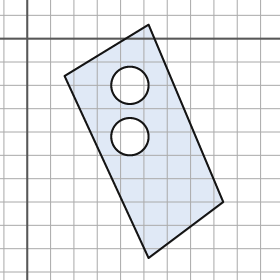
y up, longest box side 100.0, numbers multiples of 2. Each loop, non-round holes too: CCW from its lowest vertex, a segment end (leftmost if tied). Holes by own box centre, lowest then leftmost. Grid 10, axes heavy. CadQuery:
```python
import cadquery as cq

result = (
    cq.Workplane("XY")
    .moveTo(52.0, -94.0)
    .lineTo(84.0, -70.0)
    .lineTo(52.0, 6.0)
    .lineTo(16.0, -16.0)
    .close()
    .moveTo(44.0, -42.0)
    .circle(8.0)
    .moveTo(44.0, -20.0)
    .circle(8.0)
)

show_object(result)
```